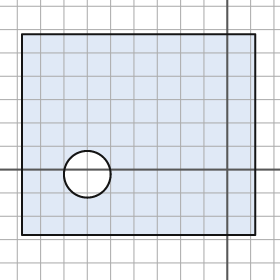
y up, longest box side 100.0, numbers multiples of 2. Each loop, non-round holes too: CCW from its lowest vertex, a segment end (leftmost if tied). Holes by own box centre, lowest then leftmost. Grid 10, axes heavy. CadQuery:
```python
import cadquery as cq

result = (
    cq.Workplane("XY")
    .moveTo(-88.0, -28.0)
    .lineTo(12.0, -28.0)
    .lineTo(12.0, 58.0)
    .lineTo(-88.0, 58.0)
    .close()
    .moveTo(-60.0, -2.0)
    .circle(10.0)
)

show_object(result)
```